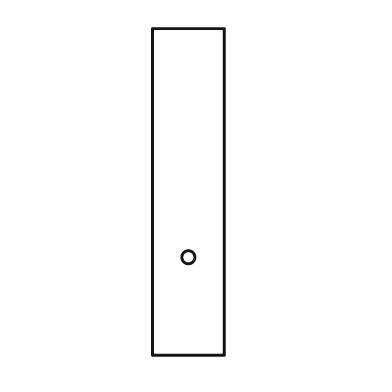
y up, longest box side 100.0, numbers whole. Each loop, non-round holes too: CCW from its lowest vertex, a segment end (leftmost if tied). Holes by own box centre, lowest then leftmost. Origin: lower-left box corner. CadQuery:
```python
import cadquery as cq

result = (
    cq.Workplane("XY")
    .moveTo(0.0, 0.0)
    .lineTo(22.0, 0.0)
    .lineTo(22.0, 100.0)
    .lineTo(0.0, 100.0)
    .close()
    .moveTo(11.0, 30.0)
    .circle(2.0)
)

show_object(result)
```